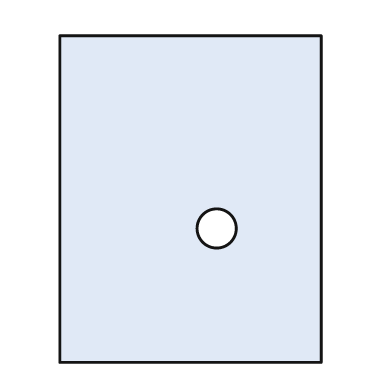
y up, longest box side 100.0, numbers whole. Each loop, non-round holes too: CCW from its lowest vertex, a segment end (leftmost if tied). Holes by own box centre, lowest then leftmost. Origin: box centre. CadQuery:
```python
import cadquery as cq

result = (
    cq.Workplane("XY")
    .moveTo(-40.0, -50.0)
    .lineTo(40.0, -50.0)
    .lineTo(40.0, 50.0)
    .lineTo(-40.0, 50.0)
    .close()
    .moveTo(8.0, -9.0)
    .circle(6.0)
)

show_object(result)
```